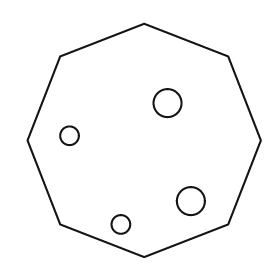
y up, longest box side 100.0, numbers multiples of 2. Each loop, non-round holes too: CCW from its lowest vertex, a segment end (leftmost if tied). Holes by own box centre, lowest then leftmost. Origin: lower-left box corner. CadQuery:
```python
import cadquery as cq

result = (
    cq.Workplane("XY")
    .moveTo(50.0, 0.0)
    .lineTo(86.0, 14.0)
    .lineTo(100.0, 50.0)
    .lineTo(86.0, 86.0)
    .lineTo(50.0, 100.0)
    .lineTo(14.0, 86.0)
    .lineTo(0.0, 50.0)
    .lineTo(14.0, 14.0)
    .close()
    .moveTo(40.0, 14.0)
    .circle(4.0)
    .moveTo(70.0, 24.0)
    .circle(6.0)
    .moveTo(18.0, 52.0)
    .circle(4.0)
    .moveTo(60.0, 66.0)
    .circle(6.0)
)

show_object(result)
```